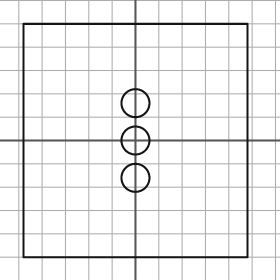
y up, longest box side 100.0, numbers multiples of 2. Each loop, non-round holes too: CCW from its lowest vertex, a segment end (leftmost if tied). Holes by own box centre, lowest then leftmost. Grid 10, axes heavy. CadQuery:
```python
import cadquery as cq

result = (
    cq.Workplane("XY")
    .moveTo(-48.0, -50.0)
    .lineTo(48.0, -50.0)
    .lineTo(48.0, 50.0)
    .lineTo(-48.0, 50.0)
    .close()
    .moveTo(0.0, -16.0)
    .circle(6.0)
    .moveTo(0.0, 0.0)
    .circle(6.0)
    .moveTo(0.0, 16.0)
    .circle(6.0)
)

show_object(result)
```